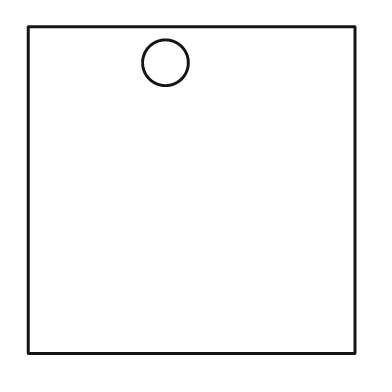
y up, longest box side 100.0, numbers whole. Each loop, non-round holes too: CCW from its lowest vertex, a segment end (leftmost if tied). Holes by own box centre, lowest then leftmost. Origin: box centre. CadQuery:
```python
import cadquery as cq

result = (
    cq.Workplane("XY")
    .moveTo(-50.0, -50.0)
    .lineTo(50.0, -50.0)
    .lineTo(50.0, 50.0)
    .lineTo(-50.0, 50.0)
    .close()
    .moveTo(-8.0, 39.0)
    .circle(7.0)
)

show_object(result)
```